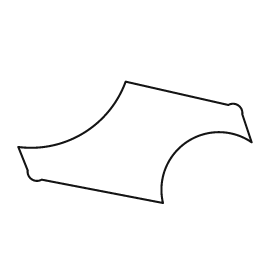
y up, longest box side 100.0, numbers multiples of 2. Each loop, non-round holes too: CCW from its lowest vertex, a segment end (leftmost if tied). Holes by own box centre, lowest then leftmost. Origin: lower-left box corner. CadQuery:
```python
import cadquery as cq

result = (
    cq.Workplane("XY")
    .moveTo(62.0, 0.0)
    .threePointArc((72.0, 26.0), (100.0, 26.0))
    .lineTo(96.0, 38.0)
    .threePointArc((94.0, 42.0), (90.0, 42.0))
    .lineTo(46.0, 52.0)
    .threePointArc((28.0, 30.0), (0.0, 24.0))
    .lineTo(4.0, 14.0)
    .threePointArc((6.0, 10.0), (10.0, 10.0))
    .close()
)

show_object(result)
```